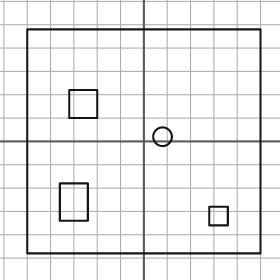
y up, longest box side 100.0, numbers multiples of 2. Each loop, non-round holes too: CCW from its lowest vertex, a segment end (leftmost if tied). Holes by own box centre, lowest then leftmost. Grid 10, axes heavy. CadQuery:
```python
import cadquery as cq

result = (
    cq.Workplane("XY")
    .moveTo(-50.0, -48.0)
    .lineTo(50.0, -48.0)
    .lineTo(50.0, 48.0)
    .lineTo(-50.0, 48.0)
    .close()
    .moveTo(28.0, -36.0)
    .lineTo(36.0, -36.0)
    .lineTo(36.0, -28.0)
    .lineTo(28.0, -28.0)
    .close()
    .moveTo(-36.0, -34.0)
    .lineTo(-24.0, -34.0)
    .lineTo(-24.0, -18.0)
    .lineTo(-36.0, -18.0)
    .close()
    .moveTo(8.0, 2.0)
    .circle(4.0)
    .moveTo(-32.0, 10.0)
    .lineTo(-20.0, 10.0)
    .lineTo(-20.0, 22.0)
    .lineTo(-32.0, 22.0)
    .close()
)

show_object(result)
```